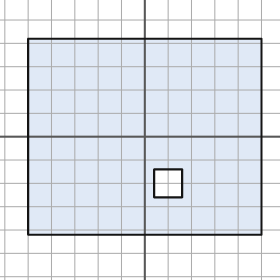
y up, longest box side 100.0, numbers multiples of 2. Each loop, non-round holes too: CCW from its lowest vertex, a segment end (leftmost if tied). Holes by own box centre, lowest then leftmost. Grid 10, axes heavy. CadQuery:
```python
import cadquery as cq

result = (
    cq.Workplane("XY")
    .moveTo(-50.0, -42.0)
    .lineTo(50.0, -42.0)
    .lineTo(50.0, 42.0)
    .lineTo(-50.0, 42.0)
    .close()
    .moveTo(4.0, -26.0)
    .lineTo(16.0, -26.0)
    .lineTo(16.0, -14.0)
    .lineTo(4.0, -14.0)
    .close()
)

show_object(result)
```